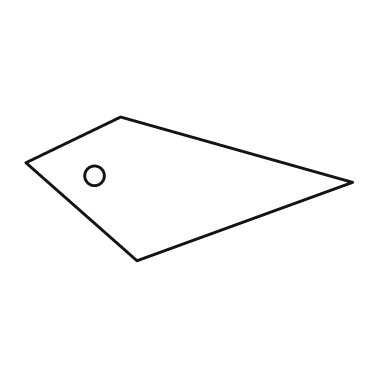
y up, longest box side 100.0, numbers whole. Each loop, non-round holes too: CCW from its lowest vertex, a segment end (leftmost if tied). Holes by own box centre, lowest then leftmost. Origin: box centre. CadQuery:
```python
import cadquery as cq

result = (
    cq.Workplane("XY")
    .moveTo(-16.0, -22.0)
    .lineTo(50.0, 2.0)
    .lineTo(-21.0, 22.0)
    .lineTo(-50.0, 8.0)
    .close()
    .moveTo(-29.0, 4.0)
    .circle(3.0)
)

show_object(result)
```